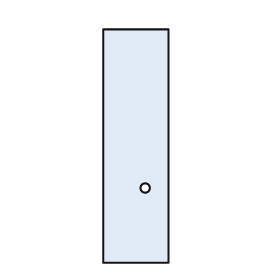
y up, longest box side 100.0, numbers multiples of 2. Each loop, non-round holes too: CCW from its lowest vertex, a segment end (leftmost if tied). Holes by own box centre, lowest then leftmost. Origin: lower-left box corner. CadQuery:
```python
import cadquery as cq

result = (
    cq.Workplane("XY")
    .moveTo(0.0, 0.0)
    .lineTo(28.0, 0.0)
    .lineTo(28.0, 100.0)
    .lineTo(0.0, 100.0)
    .close()
    .moveTo(18.0, 32.0)
    .circle(2.0)
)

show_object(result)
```